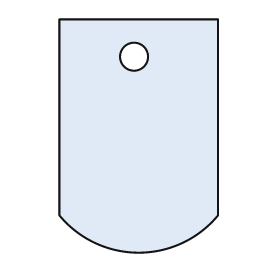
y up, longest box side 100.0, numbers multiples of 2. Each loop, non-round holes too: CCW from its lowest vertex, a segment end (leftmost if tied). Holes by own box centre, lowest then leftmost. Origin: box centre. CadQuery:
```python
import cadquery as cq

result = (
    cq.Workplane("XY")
    .moveTo(-34.0, -34.0)
    .threePointArc((0.0, -50.0), (34.0, -34.0))
    .lineTo(34.0, 50.0)
    .lineTo(-34.0, 50.0)
    .close()
    .moveTo(-2.0, 34.0)
    .circle(6.0)
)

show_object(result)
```